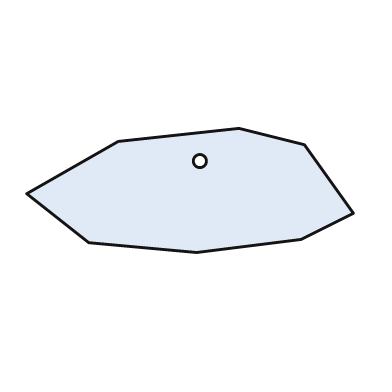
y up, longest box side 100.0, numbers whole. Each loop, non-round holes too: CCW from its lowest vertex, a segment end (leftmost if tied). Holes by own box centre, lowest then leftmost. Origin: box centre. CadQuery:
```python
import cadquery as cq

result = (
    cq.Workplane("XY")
    .moveTo(2.0, -19.0)
    .lineTo(34.0, -15.0)
    .lineTo(50.0, -7.0)
    .lineTo(35.0, 14.0)
    .lineTo(15.0, 19.0)
    .lineTo(-22.0, 15.0)
    .lineTo(-50.0, -1.0)
    .lineTo(-31.0, -16.0)
    .close()
    .moveTo(3.0, 9.0)
    .circle(2.0)
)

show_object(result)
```